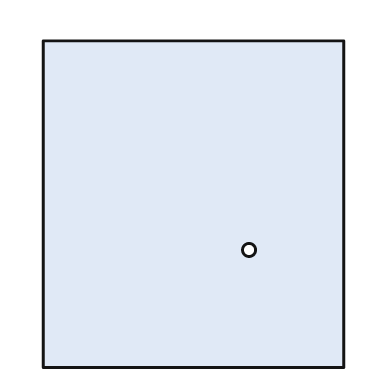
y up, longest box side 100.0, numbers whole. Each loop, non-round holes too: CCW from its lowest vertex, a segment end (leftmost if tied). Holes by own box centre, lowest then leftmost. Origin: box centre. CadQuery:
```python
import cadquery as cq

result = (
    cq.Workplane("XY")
    .moveTo(-46.0, -50.0)
    .lineTo(46.0, -50.0)
    .lineTo(46.0, 50.0)
    .lineTo(-46.0, 50.0)
    .close()
    .moveTo(17.0, -14.0)
    .circle(2.0)
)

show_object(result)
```